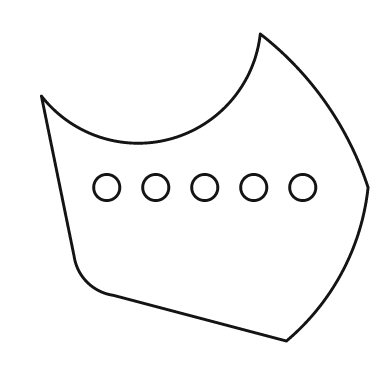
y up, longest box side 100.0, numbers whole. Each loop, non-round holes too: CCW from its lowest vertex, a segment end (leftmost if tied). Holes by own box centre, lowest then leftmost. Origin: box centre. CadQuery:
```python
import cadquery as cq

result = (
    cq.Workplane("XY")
    .moveTo(25.0, -47.0)
    .threePointArc((42.0, -26.0), (50.0, 0.0))
    .threePointArc((37.0, 26.0), (17.0, 47.0))
    .threePointArc((-10.0, 15.0), (-50.0, 28.0))
    .lineTo(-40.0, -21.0)
    .threePointArc((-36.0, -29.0), (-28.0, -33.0))
    .close()
    .moveTo(-30.0, 0.0)
    .circle(4.0)
    .moveTo(-15.0, 0.0)
    .circle(4.0)
    .moveTo(0.0, 0.0)
    .circle(4.0)
    .moveTo(15.0, 0.0)
    .circle(4.0)
    .moveTo(30.0, 0.0)
    .circle(4.0)
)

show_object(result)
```